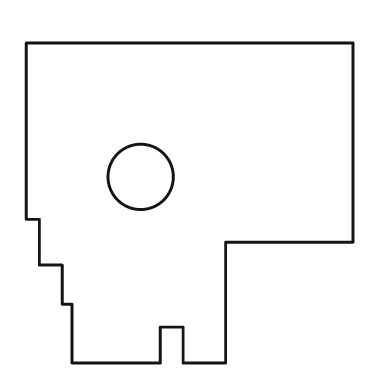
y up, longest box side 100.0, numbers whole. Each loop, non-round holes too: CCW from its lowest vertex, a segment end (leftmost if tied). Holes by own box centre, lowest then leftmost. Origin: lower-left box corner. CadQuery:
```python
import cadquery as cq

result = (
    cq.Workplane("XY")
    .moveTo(14.0, 0.0)
    .lineTo(41.0, 0.0)
    .lineTo(41.0, 11.0)
    .lineTo(48.0, 11.0)
    .lineTo(48.0, 0.0)
    .lineTo(61.0, 0.0)
    .lineTo(61.0, 37.0)
    .lineTo(100.0, 37.0)
    .lineTo(100.0, 98.0)
    .lineTo(0.0, 98.0)
    .lineTo(0.0, 44.0)
    .lineTo(4.0, 44.0)
    .lineTo(4.0, 30.0)
    .lineTo(11.0, 30.0)
    .lineTo(11.0, 18.0)
    .lineTo(14.0, 18.0)
    .close()
    .moveTo(35.0, 57.0)
    .circle(10.0)
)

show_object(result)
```